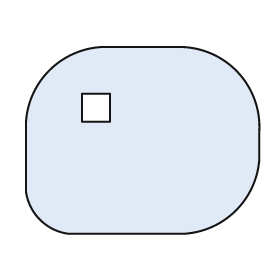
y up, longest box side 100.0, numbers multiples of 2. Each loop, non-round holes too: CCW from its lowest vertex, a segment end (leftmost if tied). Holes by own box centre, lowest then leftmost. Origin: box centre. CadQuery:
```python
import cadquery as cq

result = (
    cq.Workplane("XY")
    .moveTo(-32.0, -40.0)
    .lineTo(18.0, -40.0)
    .threePointArc((40.0, -30.0), (50.0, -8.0))
    .lineTo(50.0, 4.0)
    .threePointArc((40.0, 30.0), (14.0, 40.0))
    .lineTo(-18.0, 40.0)
    .threePointArc((-40.0, 30.0), (-50.0, 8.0))
    .lineTo(-50.0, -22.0)
    .threePointArc((-44.0, -34.0), (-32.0, -40.0))
    .close()
    .moveTo(-26.0, 8.0)
    .lineTo(-14.0, 8.0)
    .lineTo(-14.0, 20.0)
    .lineTo(-26.0, 20.0)
    .close()
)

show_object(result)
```